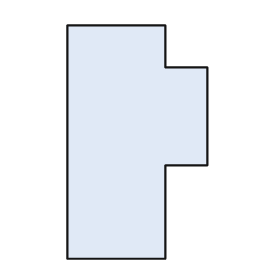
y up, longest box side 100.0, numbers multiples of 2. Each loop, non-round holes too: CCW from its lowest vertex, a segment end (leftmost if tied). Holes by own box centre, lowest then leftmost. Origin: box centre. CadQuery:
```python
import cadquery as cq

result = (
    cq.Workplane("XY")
    .moveTo(-30.0, -50.0)
    .lineTo(12.0, -50.0)
    .lineTo(12.0, -10.0)
    .lineTo(30.0, -10.0)
    .lineTo(30.0, 32.0)
    .lineTo(12.0, 32.0)
    .lineTo(12.0, 50.0)
    .lineTo(-30.0, 50.0)
    .close()
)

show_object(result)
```